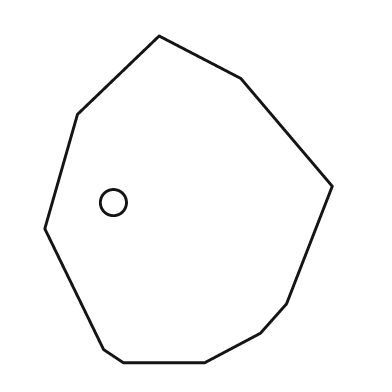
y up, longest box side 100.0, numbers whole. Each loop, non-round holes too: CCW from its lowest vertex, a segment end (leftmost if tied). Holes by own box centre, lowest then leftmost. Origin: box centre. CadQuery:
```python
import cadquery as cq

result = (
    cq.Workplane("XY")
    .moveTo(-20.0, -50.0)
    .lineTo(5.0, -50.0)
    .lineTo(22.0, -41.0)
    .lineTo(30.0, -32.0)
    .lineTo(44.0, 4.0)
    .lineTo(16.0, 37.0)
    .lineTo(-9.0, 50.0)
    .lineTo(-34.0, 26.0)
    .lineTo(-44.0, -9.0)
    .lineTo(-26.0, -46.0)
    .close()
    .moveTo(-23.0, -1.0)
    .circle(4.0)
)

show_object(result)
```